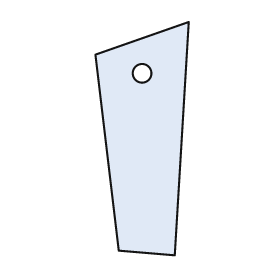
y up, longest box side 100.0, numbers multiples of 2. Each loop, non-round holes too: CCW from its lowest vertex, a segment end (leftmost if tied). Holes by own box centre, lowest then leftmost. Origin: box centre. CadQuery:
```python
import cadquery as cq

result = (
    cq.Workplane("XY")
    .moveTo(14.0, -50.0)
    .lineTo(20.0, 50.0)
    .lineTo(-20.0, 36.0)
    .lineTo(-10.0, -48.0)
    .close()
    .moveTo(0.0, 28.0)
    .circle(4.0)
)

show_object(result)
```